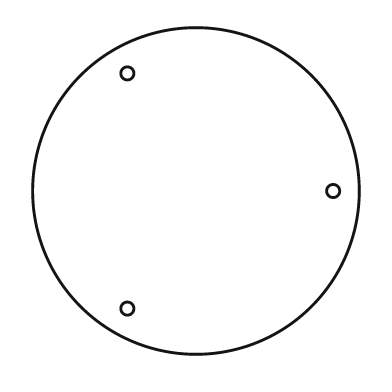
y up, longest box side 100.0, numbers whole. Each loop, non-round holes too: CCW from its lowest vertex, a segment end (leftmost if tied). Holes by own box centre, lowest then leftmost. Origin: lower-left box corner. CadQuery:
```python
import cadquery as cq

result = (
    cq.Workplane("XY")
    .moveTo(50.0, 50.0)
    .circle(50.0)
    .moveTo(29.0, 14.0)
    .circle(2.0)
    .moveTo(92.0, 50.0)
    .circle(2.0)
    .moveTo(29.0, 86.0)
    .circle(2.0)
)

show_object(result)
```